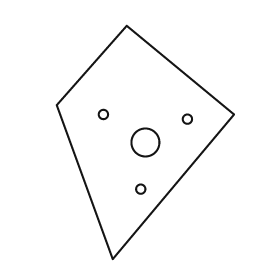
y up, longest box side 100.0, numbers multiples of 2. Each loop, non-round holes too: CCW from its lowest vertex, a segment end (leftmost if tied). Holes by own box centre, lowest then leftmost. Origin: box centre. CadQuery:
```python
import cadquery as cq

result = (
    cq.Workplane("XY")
    .moveTo(-14.0, -50.0)
    .lineTo(38.0, 12.0)
    .lineTo(-8.0, 50.0)
    .lineTo(-38.0, 16.0)
    .close()
    .moveTo(-2.0, -20.0)
    .circle(2.0)
    .moveTo(0.0, 0.0)
    .circle(6.0)
    .moveTo(18.0, 10.0)
    .circle(2.0)
    .moveTo(-18.0, 12.0)
    .circle(2.0)
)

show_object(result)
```